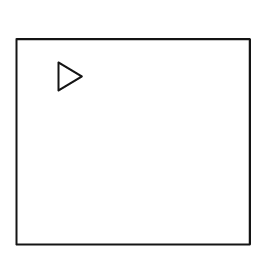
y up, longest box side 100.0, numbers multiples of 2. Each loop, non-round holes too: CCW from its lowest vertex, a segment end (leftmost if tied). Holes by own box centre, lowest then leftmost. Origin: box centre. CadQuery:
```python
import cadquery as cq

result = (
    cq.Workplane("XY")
    .moveTo(-50.0, -44.0)
    .lineTo(50.0, -44.0)
    .lineTo(50.0, 44.0)
    .lineTo(-50.0, 44.0)
    .close()
    .moveTo(-32.0, 22.0)
    .lineTo(-22.0, 28.0)
    .lineTo(-32.0, 34.0)
    .close()
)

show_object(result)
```